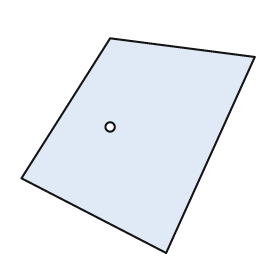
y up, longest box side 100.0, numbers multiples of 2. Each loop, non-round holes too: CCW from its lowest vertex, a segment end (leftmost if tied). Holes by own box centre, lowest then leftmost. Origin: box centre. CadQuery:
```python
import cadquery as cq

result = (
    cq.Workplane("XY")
    .moveTo(12.0, -46.0)
    .lineTo(50.0, 38.0)
    .lineTo(-12.0, 46.0)
    .lineTo(-50.0, -14.0)
    .close()
    .moveTo(-12.0, 8.0)
    .circle(2.0)
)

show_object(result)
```